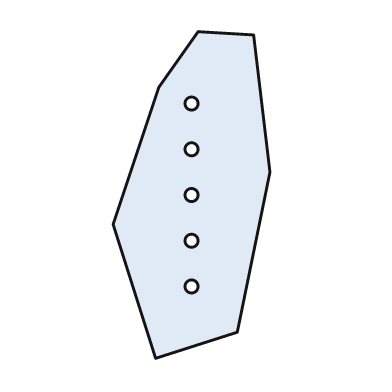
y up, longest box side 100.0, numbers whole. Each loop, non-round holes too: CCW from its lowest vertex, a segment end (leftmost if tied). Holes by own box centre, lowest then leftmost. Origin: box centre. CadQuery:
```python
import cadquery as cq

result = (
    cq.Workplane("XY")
    .moveTo(-11.0, -50.0)
    .lineTo(14.0, -42.0)
    .lineTo(24.0, 7.0)
    .lineTo(19.0, 49.0)
    .lineTo(2.0, 50.0)
    .lineTo(-10.0, 33.0)
    .lineTo(-24.0, -9.0)
    .close()
    .moveTo(0.0, -28.0)
    .circle(2.0)
    .moveTo(0.0, -14.0)
    .circle(2.0)
    .moveTo(0.0, 0.0)
    .circle(2.0)
    .moveTo(0.0, 14.0)
    .circle(2.0)
    .moveTo(0.0, 28.0)
    .circle(2.0)
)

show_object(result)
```